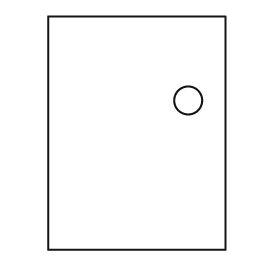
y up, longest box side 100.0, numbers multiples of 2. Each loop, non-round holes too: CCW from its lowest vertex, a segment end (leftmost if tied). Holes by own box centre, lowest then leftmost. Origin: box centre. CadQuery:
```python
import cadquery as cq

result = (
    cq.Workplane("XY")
    .moveTo(-38.0, -50.0)
    .lineTo(38.0, -50.0)
    .lineTo(38.0, 50.0)
    .lineTo(-38.0, 50.0)
    .close()
    .moveTo(22.0, 14.0)
    .circle(6.0)
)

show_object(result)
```